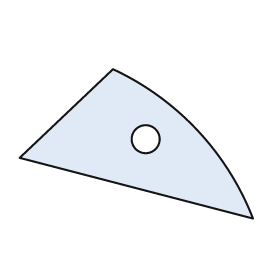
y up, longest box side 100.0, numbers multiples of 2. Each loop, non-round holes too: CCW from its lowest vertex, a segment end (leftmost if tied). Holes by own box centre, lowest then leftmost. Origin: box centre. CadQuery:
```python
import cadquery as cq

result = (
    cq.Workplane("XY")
    .moveTo(50.0, -32.0)
    .threePointArc((26.0, 6.0), (-10.0, 32.0))
    .lineTo(-50.0, -6.0)
    .close()
    .moveTo(4.0, 2.0)
    .circle(6.0)
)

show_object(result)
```